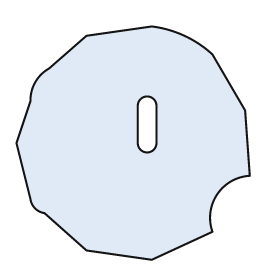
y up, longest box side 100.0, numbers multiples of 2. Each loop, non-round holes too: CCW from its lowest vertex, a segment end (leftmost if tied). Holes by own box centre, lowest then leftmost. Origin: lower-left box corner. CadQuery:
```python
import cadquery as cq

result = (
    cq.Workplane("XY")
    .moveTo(58.0, 0.0)
    .lineTo(84.0, 12.0)
    .threePointArc((86.0, 28.0), (100.0, 36.0))
    .lineTo(98.0, 64.0)
    .lineTo(84.0, 88.0)
    .threePointArc((72.0, 96.0), (58.0, 100.0))
    .lineTo(30.0, 96.0)
    .lineTo(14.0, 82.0)
    .threePointArc((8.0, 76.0), (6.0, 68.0))
    .lineTo(0.0, 50.0)
    .lineTo(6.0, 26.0)
    .threePointArc((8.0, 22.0), (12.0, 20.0))
    .lineTo(30.0, 4.0)
    .close()
    .moveTo(52.0, 50.0)
    .threePointArc((56.0, 46.0), (60.0, 50.0))
    .lineTo(60.0, 66.0)
    .threePointArc((56.0, 70.0), (52.0, 66.0))
    .close()
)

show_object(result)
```